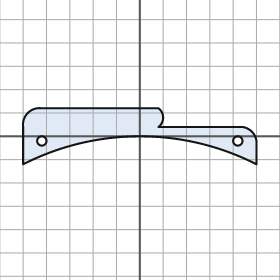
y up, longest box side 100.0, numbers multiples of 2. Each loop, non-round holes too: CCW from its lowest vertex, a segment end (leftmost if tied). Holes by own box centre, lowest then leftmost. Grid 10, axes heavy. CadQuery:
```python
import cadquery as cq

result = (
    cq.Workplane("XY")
    .moveTo(-50.0, -12.0)
    .threePointArc((0.0, 0.0), (50.0, -12.0))
    .lineTo(50.0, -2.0)
    .threePointArc((48.0, 2.0), (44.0, 4.0))
    .lineTo(8.0, 4.0)
    .threePointArc((10.0, 8.0), (8.0, 12.0))
    .lineTo(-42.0, 12.0)
    .threePointArc((-48.0, 10.0), (-50.0, 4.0))
    .close()
    .moveTo(-42.0, -2.0)
    .circle(2.0)
    .moveTo(42.0, -2.0)
    .circle(2.0)
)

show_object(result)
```